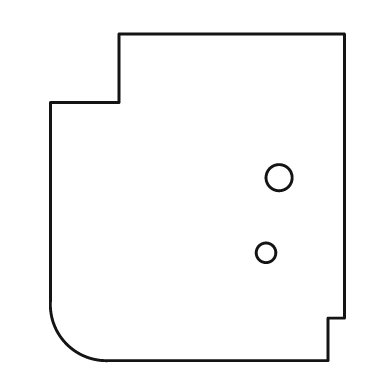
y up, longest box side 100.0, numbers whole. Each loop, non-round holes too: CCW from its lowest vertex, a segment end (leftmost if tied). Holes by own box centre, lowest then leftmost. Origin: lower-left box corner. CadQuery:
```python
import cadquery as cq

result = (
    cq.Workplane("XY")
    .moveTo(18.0, 0.0)
    .lineTo(85.0, 0.0)
    .lineTo(85.0, 13.0)
    .lineTo(90.0, 13.0)
    .lineTo(90.0, 100.0)
    .lineTo(21.0, 100.0)
    .lineTo(21.0, 79.0)
    .lineTo(0.0, 79.0)
    .lineTo(0.0, 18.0)
    .threePointArc((5.0, 5.0), (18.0, 0.0))
    .close()
    .moveTo(66.0, 33.0)
    .circle(3.0)
    .moveTo(70.0, 56.0)
    .circle(4.0)
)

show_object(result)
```